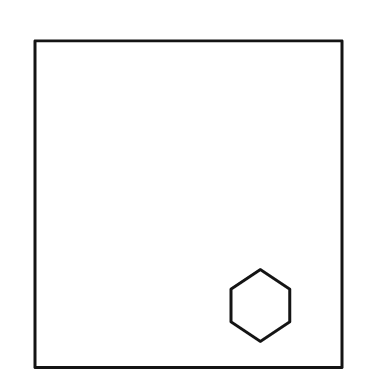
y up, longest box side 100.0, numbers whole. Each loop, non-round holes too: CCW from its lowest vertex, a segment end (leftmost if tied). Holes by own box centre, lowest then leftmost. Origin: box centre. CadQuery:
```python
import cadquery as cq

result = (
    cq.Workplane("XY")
    .moveTo(-47.0, -50.0)
    .lineTo(47.0, -50.0)
    .lineTo(47.0, 50.0)
    .lineTo(-47.0, 50.0)
    .close()
    .moveTo(22.0, -42.0)
    .lineTo(31.0, -36.0)
    .lineTo(31.0, -26.0)
    .lineTo(22.0, -20.0)
    .lineTo(13.0, -26.0)
    .lineTo(13.0, -36.0)
    .close()
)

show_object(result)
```